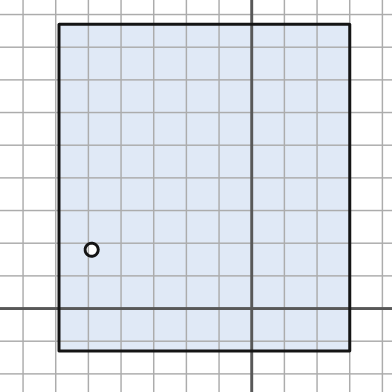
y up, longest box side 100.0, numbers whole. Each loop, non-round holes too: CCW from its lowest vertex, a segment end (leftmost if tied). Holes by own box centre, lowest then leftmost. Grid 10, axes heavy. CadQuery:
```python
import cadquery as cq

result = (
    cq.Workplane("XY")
    .moveTo(-59.0, -13.0)
    .lineTo(30.0, -13.0)
    .lineTo(30.0, 87.0)
    .lineTo(-59.0, 87.0)
    .close()
    .moveTo(-49.0, 18.0)
    .circle(2.0)
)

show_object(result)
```